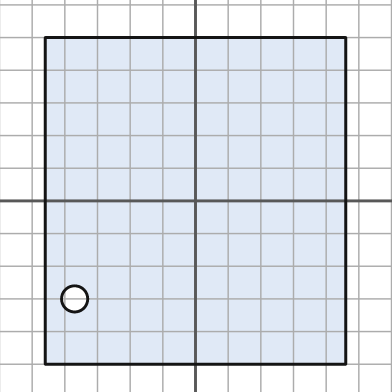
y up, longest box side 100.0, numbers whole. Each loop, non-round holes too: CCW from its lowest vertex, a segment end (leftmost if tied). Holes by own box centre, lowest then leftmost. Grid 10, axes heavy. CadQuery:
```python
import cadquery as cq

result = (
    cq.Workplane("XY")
    .moveTo(-46.0, -50.0)
    .lineTo(46.0, -50.0)
    .lineTo(46.0, 50.0)
    .lineTo(-46.0, 50.0)
    .close()
    .moveTo(-37.0, -30.0)
    .circle(4.0)
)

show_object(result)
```